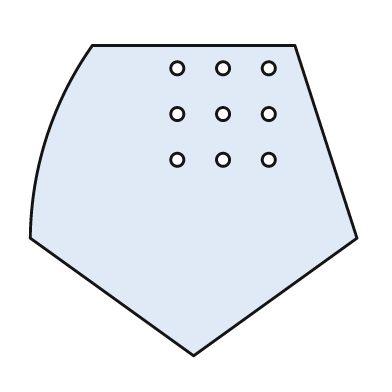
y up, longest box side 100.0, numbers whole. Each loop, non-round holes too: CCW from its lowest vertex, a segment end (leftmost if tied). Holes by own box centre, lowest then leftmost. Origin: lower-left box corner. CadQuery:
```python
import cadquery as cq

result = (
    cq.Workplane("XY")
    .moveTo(50.0, 0.0)
    .lineTo(100.0, 36.0)
    .lineTo(81.0, 95.0)
    .lineTo(19.0, 95.0)
    .threePointArc((5.0, 67.0), (0.0, 36.0))
    .close()
    .moveTo(45.0, 60.0)
    .circle(2.0)
    .moveTo(59.0, 60.0)
    .circle(2.0)
    .moveTo(73.0, 60.0)
    .circle(2.0)
    .moveTo(45.0, 74.0)
    .circle(2.0)
    .moveTo(59.0, 74.0)
    .circle(2.0)
    .moveTo(73.0, 74.0)
    .circle(2.0)
    .moveTo(45.0, 88.0)
    .circle(2.0)
    .moveTo(59.0, 88.0)
    .circle(2.0)
    .moveTo(73.0, 88.0)
    .circle(2.0)
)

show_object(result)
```